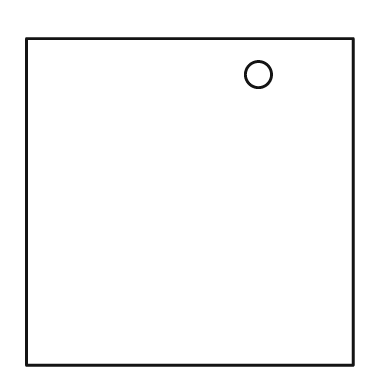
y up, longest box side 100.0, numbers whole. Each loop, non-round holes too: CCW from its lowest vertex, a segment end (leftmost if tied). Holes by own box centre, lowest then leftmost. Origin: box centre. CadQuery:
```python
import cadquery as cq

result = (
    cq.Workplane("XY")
    .moveTo(-50.0, -50.0)
    .lineTo(50.0, -50.0)
    .lineTo(50.0, 50.0)
    .lineTo(-50.0, 50.0)
    .close()
    .moveTo(21.0, 39.0)
    .circle(4.0)
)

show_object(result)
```